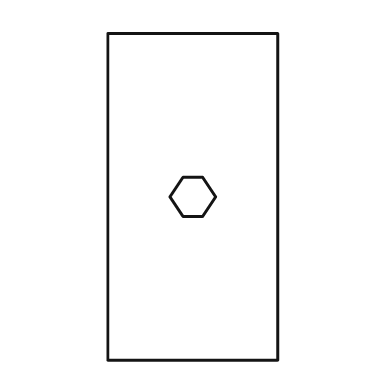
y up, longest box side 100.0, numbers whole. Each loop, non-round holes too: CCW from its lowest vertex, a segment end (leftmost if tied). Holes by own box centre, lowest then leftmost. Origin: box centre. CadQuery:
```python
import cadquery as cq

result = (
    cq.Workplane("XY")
    .moveTo(-26.0, -50.0)
    .lineTo(26.0, -50.0)
    .lineTo(26.0, 50.0)
    .lineTo(-26.0, 50.0)
    .close()
    .moveTo(-3.0, -6.0)
    .lineTo(3.0, -6.0)
    .lineTo(7.0, 0.0)
    .lineTo(3.0, 6.0)
    .lineTo(-3.0, 6.0)
    .lineTo(-7.0, 0.0)
    .close()
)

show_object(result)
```